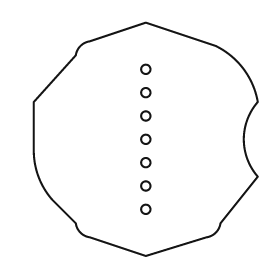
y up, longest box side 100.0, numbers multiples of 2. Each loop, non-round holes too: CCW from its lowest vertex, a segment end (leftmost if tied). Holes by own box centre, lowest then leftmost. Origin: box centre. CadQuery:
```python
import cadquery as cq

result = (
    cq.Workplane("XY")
    .moveTo(0.0, -50.0)
    .lineTo(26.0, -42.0)
    .threePointArc((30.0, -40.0), (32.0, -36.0))
    .lineTo(48.0, -16.0)
    .threePointArc((42.0, 0.0), (48.0, 16.0))
    .threePointArc((42.0, 30.0), (30.0, 40.0))
    .lineTo(0.0, 50.0)
    .lineTo(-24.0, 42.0)
    .threePointArc((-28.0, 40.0), (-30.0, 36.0))
    .lineTo(-48.0, 16.0)
    .lineTo(-48.0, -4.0)
    .threePointArc((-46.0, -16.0), (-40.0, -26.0))
    .lineTo(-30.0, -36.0)
    .threePointArc((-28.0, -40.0), (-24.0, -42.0))
    .close()
    .moveTo(0.0, -30.0)
    .circle(2.0)
    .moveTo(0.0, -20.0)
    .circle(2.0)
    .moveTo(0.0, -10.0)
    .circle(2.0)
    .moveTo(0.0, 0.0)
    .circle(2.0)
    .moveTo(0.0, 10.0)
    .circle(2.0)
    .moveTo(0.0, 20.0)
    .circle(2.0)
    .moveTo(0.0, 30.0)
    .circle(2.0)
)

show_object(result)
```